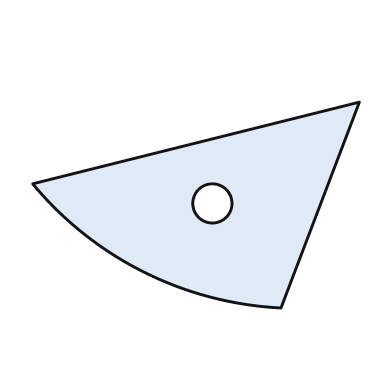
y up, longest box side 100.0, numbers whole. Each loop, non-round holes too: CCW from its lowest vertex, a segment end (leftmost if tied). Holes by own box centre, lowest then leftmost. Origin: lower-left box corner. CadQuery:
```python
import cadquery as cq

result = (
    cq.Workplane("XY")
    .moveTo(76.0, 0.0)
    .lineTo(100.0, 63.0)
    .lineTo(0.0, 38.0)
    .threePointArc((34.0, 11.0), (76.0, 0.0))
    .close()
    .moveTo(55.0, 32.0)
    .circle(6.0)
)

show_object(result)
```